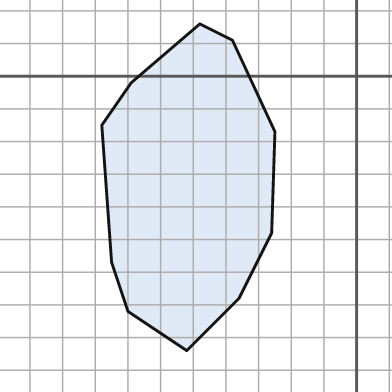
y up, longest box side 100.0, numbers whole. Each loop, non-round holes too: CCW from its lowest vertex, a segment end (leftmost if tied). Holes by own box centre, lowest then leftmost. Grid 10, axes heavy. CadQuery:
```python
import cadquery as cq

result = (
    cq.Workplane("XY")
    .moveTo(-52.0, -84.0)
    .lineTo(-36.0, -68.0)
    .lineTo(-26.0, -48.0)
    .lineTo(-25.0, -17.0)
    .lineTo(-38.0, 11.0)
    .lineTo(-48.0, 16.0)
    .lineTo(-69.0, -2.0)
    .lineTo(-78.0, -15.0)
    .lineTo(-75.0, -57.0)
    .lineTo(-70.0, -72.0)
    .close()
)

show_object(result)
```